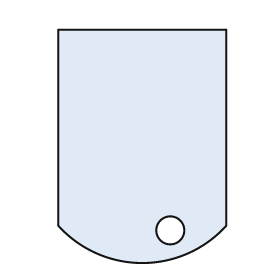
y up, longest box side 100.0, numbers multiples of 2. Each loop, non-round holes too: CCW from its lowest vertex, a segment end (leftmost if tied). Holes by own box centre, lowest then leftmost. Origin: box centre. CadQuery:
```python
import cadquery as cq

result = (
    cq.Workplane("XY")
    .moveTo(-36.0, -34.0)
    .threePointArc((0.0, -50.0), (36.0, -34.0))
    .lineTo(36.0, 50.0)
    .lineTo(-36.0, 50.0)
    .close()
    .moveTo(12.0, -36.0)
    .circle(6.0)
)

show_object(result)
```